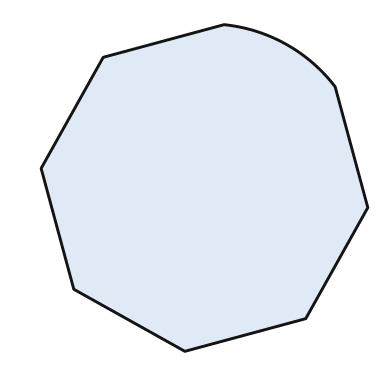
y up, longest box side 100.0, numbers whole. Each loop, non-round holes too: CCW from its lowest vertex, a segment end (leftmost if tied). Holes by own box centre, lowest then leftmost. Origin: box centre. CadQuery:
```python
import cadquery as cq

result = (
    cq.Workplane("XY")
    .moveTo(-6.0, -50.0)
    .lineTo(31.0, -40.0)
    .lineTo(50.0, -6.0)
    .lineTo(40.0, 31.0)
    .threePointArc((25.0, 44.0), (6.0, 50.0))
    .lineTo(-31.0, 40.0)
    .lineTo(-50.0, 6.0)
    .lineTo(-40.0, -31.0)
    .close()
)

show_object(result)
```